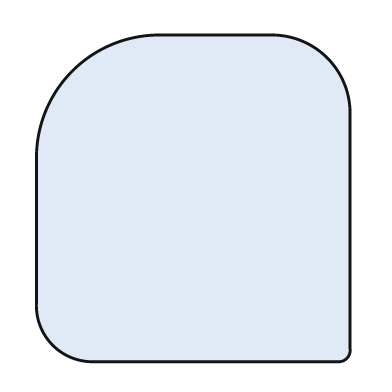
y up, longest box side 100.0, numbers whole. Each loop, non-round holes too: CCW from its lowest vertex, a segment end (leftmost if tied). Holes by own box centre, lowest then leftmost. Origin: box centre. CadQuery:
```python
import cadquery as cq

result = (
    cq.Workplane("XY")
    .moveTo(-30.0, -50.0)
    .lineTo(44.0, -50.0)
    .threePointArc((47.0, -49.0), (48.0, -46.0))
    .lineTo(48.0, 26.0)
    .threePointArc((41.0, 43.0), (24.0, 50.0))
    .lineTo(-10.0, 50.0)
    .threePointArc((-37.0, 39.0), (-48.0, 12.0))
    .lineTo(-48.0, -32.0)
    .threePointArc((-43.0, -45.0), (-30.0, -50.0))
    .close()
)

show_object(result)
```